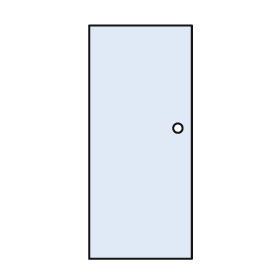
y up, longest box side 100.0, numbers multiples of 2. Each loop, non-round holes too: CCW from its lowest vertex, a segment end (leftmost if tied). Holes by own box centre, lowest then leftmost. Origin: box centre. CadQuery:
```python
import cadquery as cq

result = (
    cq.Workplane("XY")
    .moveTo(-22.0, -50.0)
    .lineTo(22.0, -50.0)
    .lineTo(22.0, 50.0)
    .lineTo(-22.0, 50.0)
    .close()
    .moveTo(16.0, 6.0)
    .circle(2.0)
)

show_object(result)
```